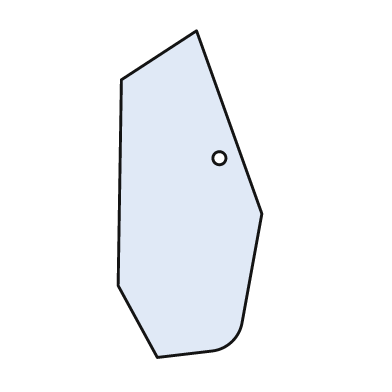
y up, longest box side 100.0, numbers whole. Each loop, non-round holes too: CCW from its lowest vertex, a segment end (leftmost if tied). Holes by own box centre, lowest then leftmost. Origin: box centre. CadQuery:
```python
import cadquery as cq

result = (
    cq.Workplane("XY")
    .moveTo(-10.0, -50.0)
    .lineTo(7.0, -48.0)
    .threePointArc((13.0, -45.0), (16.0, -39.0))
    .lineTo(22.0, -6.0)
    .lineTo(2.0, 50.0)
    .lineTo(-21.0, 35.0)
    .lineTo(-22.0, -28.0)
    .close()
    .moveTo(9.0, 11.0)
    .circle(2.0)
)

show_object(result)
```